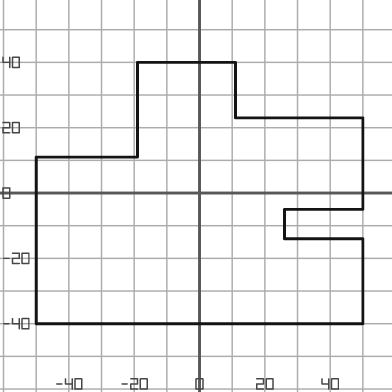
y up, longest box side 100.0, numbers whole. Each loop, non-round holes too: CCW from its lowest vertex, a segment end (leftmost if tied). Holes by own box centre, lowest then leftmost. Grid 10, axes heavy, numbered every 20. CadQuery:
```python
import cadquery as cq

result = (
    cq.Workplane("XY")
    .moveTo(-50.0, -40.0)
    .lineTo(50.0, -40.0)
    .lineTo(50.0, -14.0)
    .lineTo(26.0, -14.0)
    .lineTo(26.0, -5.0)
    .lineTo(50.0, -5.0)
    .lineTo(50.0, 23.0)
    .lineTo(11.0, 23.0)
    .lineTo(11.0, 40.0)
    .lineTo(-19.0, 40.0)
    .lineTo(-19.0, 11.0)
    .lineTo(-50.0, 11.0)
    .close()
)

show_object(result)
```